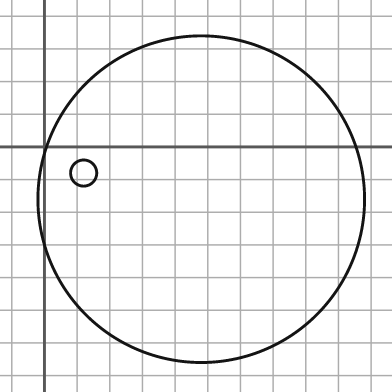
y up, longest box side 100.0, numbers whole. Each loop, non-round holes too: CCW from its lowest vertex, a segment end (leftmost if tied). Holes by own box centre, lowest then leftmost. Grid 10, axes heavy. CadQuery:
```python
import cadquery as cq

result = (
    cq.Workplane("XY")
    .moveTo(48.0, -16.0)
    .circle(50.0)
    .moveTo(12.0, -8.0)
    .circle(4.0)
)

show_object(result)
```